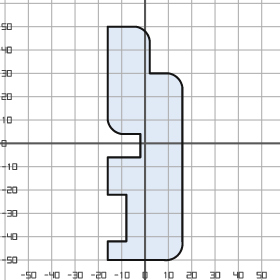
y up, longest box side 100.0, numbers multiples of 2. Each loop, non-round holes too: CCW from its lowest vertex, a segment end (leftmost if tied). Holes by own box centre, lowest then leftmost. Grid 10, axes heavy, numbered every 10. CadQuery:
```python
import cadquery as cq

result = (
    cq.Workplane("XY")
    .moveTo(-16.0, -50.0)
    .lineTo(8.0, -50.0)
    .threePointArc((14.0, -48.0), (16.0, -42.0))
    .lineTo(16.0, 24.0)
    .threePointArc((14.0, 28.0), (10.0, 30.0))
    .lineTo(2.0, 30.0)
    .lineTo(2.0, 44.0)
    .threePointArc((0.0, 48.0), (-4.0, 50.0))
    .lineTo(-16.0, 50.0)
    .lineTo(-16.0, 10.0)
    .threePointArc((-14.0, 6.0), (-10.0, 4.0))
    .lineTo(-2.0, 4.0)
    .lineTo(-2.0, -6.0)
    .lineTo(-16.0, -6.0)
    .lineTo(-16.0, -22.0)
    .lineTo(-8.0, -22.0)
    .lineTo(-8.0, -42.0)
    .lineTo(-16.0, -42.0)
    .close()
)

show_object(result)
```